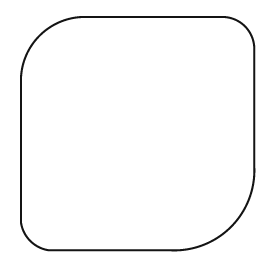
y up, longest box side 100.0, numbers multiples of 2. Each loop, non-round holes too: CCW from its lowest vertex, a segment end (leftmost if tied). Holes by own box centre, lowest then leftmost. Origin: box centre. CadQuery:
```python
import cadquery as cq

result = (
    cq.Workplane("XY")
    .moveTo(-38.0, -50.0)
    .lineTo(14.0, -50.0)
    .threePointArc((40.0, -40.0), (50.0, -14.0))
    .lineTo(50.0, 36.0)
    .threePointArc((46.0, 46.0), (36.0, 50.0))
    .lineTo(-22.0, 50.0)
    .threePointArc((-42.0, 42.0), (-50.0, 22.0))
    .lineTo(-50.0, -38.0)
    .threePointArc((-46.0, -46.0), (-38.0, -50.0))
    .close()
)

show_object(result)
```